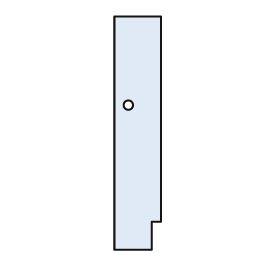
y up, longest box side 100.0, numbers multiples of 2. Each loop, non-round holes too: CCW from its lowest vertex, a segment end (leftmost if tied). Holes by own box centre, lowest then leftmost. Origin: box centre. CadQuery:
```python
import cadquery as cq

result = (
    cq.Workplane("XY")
    .moveTo(-10.0, -50.0)
    .lineTo(6.0, -50.0)
    .lineTo(6.0, -38.0)
    .lineTo(10.0, -38.0)
    .lineTo(10.0, 50.0)
    .lineTo(-10.0, 50.0)
    .close()
    .moveTo(-4.0, 12.0)
    .circle(2.0)
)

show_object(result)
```